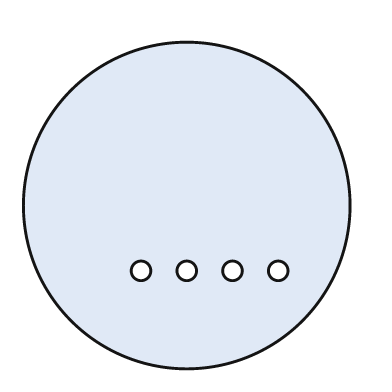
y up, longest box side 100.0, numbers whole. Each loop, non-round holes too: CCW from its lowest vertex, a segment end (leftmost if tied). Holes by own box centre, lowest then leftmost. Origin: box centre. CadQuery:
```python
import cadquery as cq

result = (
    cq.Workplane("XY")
    .moveTo(0.0, 0.0)
    .circle(50.0)
    .moveTo(-14.0, -20.0)
    .circle(3.0)
    .moveTo(0.0, -20.0)
    .circle(3.0)
    .moveTo(14.0, -20.0)
    .circle(3.0)
    .moveTo(28.0, -20.0)
    .circle(3.0)
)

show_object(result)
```